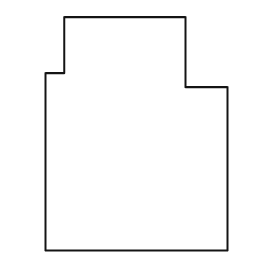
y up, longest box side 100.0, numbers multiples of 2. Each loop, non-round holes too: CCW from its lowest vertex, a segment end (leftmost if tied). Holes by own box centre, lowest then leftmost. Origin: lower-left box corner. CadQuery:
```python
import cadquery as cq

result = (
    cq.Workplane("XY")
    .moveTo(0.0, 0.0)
    .lineTo(78.0, 0.0)
    .lineTo(78.0, 70.0)
    .lineTo(60.0, 70.0)
    .lineTo(60.0, 100.0)
    .lineTo(8.0, 100.0)
    .lineTo(8.0, 76.0)
    .lineTo(0.0, 76.0)
    .close()
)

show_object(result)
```